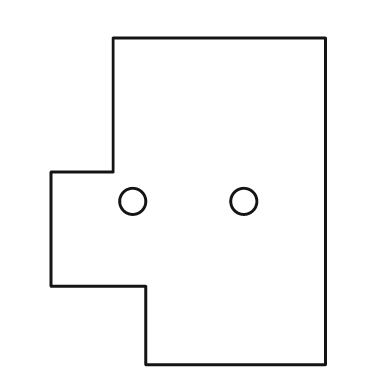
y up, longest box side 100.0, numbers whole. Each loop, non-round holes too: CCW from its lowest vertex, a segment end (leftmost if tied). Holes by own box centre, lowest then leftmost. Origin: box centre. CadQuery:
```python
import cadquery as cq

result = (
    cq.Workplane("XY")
    .moveTo(-13.0, -50.0)
    .lineTo(42.0, -50.0)
    .lineTo(42.0, 50.0)
    .lineTo(-23.0, 50.0)
    .lineTo(-23.0, 9.0)
    .lineTo(-42.0, 9.0)
    .lineTo(-42.0, -26.0)
    .lineTo(-13.0, -26.0)
    .close()
    .moveTo(-17.0, 0.0)
    .circle(4.0)
    .moveTo(17.0, 0.0)
    .circle(4.0)
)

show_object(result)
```